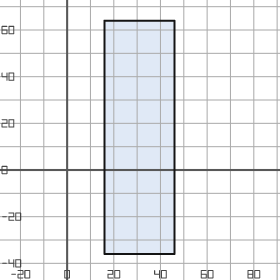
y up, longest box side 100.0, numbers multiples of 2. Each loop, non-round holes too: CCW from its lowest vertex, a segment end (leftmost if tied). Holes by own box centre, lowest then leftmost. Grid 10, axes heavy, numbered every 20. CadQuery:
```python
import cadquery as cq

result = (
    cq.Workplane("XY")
    .moveTo(16.0, -36.0)
    .lineTo(46.0, -36.0)
    .lineTo(46.0, 64.0)
    .lineTo(16.0, 64.0)
    .close()
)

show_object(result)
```